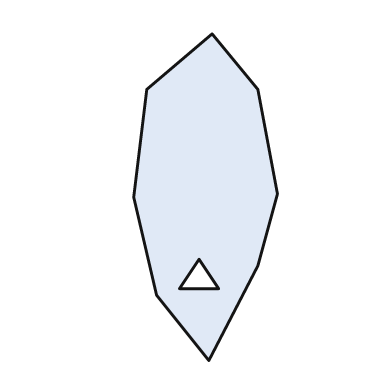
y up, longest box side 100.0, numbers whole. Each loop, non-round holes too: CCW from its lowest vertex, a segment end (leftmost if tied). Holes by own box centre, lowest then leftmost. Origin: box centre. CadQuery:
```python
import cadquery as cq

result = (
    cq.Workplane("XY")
    .moveTo(1.0, -50.0)
    .lineTo(16.0, -21.0)
    .lineTo(22.0, 1.0)
    .lineTo(16.0, 33.0)
    .lineTo(2.0, 50.0)
    .lineTo(-18.0, 33.0)
    .lineTo(-22.0, 0.0)
    .lineTo(-15.0, -30.0)
    .close()
    .moveTo(-8.0, -28.0)
    .lineTo(4.0, -28.0)
    .lineTo(-2.0, -19.0)
    .close()
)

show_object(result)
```